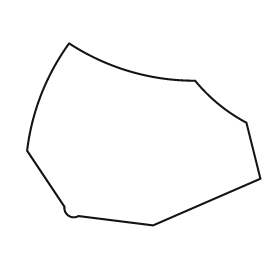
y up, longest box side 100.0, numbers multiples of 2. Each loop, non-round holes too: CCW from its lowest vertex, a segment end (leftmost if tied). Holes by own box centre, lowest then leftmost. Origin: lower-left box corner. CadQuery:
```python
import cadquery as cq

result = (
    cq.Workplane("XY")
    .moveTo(54.0, 0.0)
    .lineTo(100.0, 20.0)
    .lineTo(94.0, 44.0)
    .threePointArc((82.0, 52.0), (72.0, 62.0))
    .threePointArc((44.0, 66.0), (18.0, 78.0))
    .threePointArc((6.0, 56.0), (0.0, 32.0))
    .lineTo(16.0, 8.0)
    .threePointArc((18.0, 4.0), (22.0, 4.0))
    .close()
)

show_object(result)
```